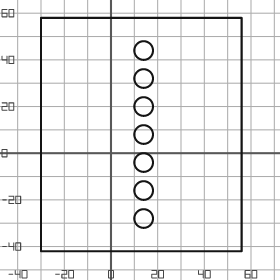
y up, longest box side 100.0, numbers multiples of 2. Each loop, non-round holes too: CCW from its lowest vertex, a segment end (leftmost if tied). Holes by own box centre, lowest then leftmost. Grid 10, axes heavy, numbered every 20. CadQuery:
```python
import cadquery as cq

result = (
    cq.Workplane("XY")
    .moveTo(-30.0, -42.0)
    .lineTo(56.0, -42.0)
    .lineTo(56.0, 58.0)
    .lineTo(-30.0, 58.0)
    .close()
    .moveTo(14.0, -28.0)
    .circle(4.0)
    .moveTo(14.0, -16.0)
    .circle(4.0)
    .moveTo(14.0, -4.0)
    .circle(4.0)
    .moveTo(14.0, 8.0)
    .circle(4.0)
    .moveTo(14.0, 20.0)
    .circle(4.0)
    .moveTo(14.0, 32.0)
    .circle(4.0)
    .moveTo(14.0, 44.0)
    .circle(4.0)
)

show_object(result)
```